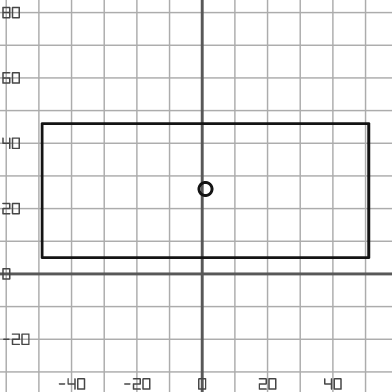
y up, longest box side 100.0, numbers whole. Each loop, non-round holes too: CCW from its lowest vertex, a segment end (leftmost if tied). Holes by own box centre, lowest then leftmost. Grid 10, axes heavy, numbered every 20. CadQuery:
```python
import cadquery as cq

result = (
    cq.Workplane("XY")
    .moveTo(-49.0, 5.0)
    .lineTo(51.0, 5.0)
    .lineTo(51.0, 46.0)
    .lineTo(-49.0, 46.0)
    .close()
    .moveTo(1.0, 26.0)
    .circle(2.0)
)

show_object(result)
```